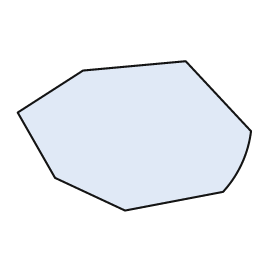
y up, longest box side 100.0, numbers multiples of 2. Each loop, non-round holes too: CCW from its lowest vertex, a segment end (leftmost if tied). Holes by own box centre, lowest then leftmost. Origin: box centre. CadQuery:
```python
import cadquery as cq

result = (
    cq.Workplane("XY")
    .moveTo(-4.0, -32.0)
    .lineTo(38.0, -24.0)
    .threePointArc((46.0, -12.0), (50.0, 2.0))
    .lineTo(22.0, 32.0)
    .lineTo(-22.0, 28.0)
    .lineTo(-50.0, 10.0)
    .lineTo(-34.0, -18.0)
    .close()
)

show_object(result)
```